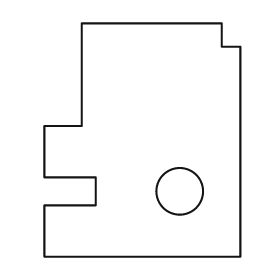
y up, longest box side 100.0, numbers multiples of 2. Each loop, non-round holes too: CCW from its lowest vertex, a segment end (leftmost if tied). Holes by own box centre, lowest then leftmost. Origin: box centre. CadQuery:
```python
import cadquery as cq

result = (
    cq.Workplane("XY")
    .moveTo(-42.0, -50.0)
    .lineTo(42.0, -50.0)
    .lineTo(42.0, 40.0)
    .lineTo(34.0, 40.0)
    .lineTo(34.0, 50.0)
    .lineTo(-26.0, 50.0)
    .lineTo(-26.0, 6.0)
    .lineTo(-42.0, 6.0)
    .lineTo(-42.0, -16.0)
    .lineTo(-20.0, -16.0)
    .lineTo(-20.0, -28.0)
    .lineTo(-42.0, -28.0)
    .close()
    .moveTo(16.0, -22.0)
    .circle(10.0)
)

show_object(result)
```